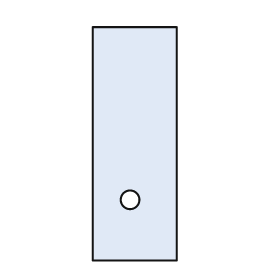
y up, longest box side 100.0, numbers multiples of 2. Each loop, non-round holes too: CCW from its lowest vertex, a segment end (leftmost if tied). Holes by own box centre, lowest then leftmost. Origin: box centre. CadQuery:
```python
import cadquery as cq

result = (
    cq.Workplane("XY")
    .moveTo(-18.0, -50.0)
    .lineTo(18.0, -50.0)
    .lineTo(18.0, 50.0)
    .lineTo(-18.0, 50.0)
    .close()
    .moveTo(-2.0, -24.0)
    .circle(4.0)
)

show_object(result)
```